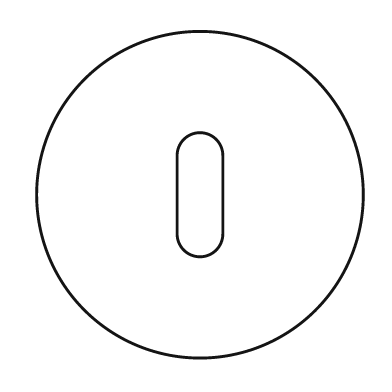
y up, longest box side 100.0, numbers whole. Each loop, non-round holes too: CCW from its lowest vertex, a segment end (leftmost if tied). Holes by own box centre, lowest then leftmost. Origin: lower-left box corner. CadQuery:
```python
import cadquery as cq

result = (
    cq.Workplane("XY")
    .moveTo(50.0, 50.0)
    .circle(50.0)
    .moveTo(43.0, 38.0)
    .threePointArc((50.0, 31.0), (57.0, 38.0))
    .lineTo(57.0, 62.0)
    .threePointArc((50.0, 69.0), (43.0, 62.0))
    .close()
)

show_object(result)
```